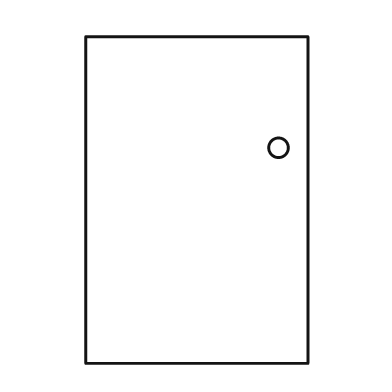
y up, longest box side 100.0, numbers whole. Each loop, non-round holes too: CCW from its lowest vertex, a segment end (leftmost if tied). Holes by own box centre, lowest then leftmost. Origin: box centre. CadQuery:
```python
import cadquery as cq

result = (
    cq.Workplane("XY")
    .moveTo(-34.0, -50.0)
    .lineTo(34.0, -50.0)
    .lineTo(34.0, 50.0)
    .lineTo(-34.0, 50.0)
    .close()
    .moveTo(25.0, 16.0)
    .circle(3.0)
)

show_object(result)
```